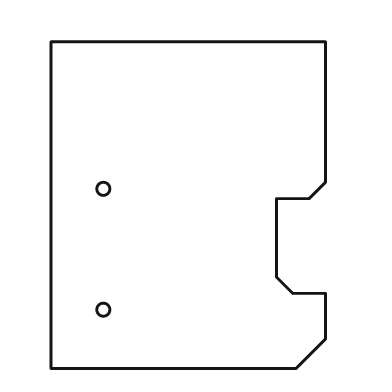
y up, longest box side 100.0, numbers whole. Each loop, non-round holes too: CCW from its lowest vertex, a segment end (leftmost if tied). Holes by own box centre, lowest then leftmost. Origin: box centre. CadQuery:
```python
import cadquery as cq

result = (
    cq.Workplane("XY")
    .moveTo(-42.0, -50.0)
    .lineTo(33.0, -50.0)
    .lineTo(42.0, -41.0)
    .lineTo(42.0, -27.0)
    .lineTo(32.0, -27.0)
    .lineTo(27.0, -22.0)
    .lineTo(27.0, 2.0)
    .lineTo(37.0, 2.0)
    .lineTo(42.0, 7.0)
    .lineTo(42.0, 50.0)
    .lineTo(-42.0, 50.0)
    .close()
    .moveTo(-26.0, -32.0)
    .circle(2.0)
    .moveTo(-26.0, 5.0)
    .circle(2.0)
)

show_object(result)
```